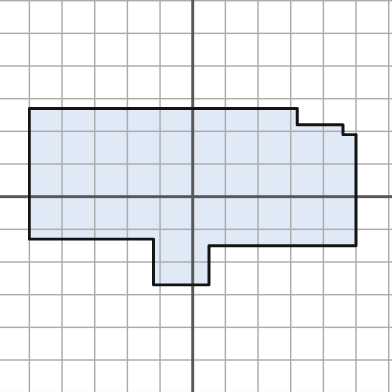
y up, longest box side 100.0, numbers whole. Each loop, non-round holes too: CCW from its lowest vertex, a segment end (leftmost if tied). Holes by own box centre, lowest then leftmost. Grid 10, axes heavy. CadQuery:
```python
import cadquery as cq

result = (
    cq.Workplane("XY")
    .moveTo(-12.0, -27.0)
    .lineTo(5.0, -27.0)
    .lineTo(5.0, -15.0)
    .lineTo(50.0, -15.0)
    .lineTo(50.0, 19.0)
    .lineTo(46.0, 19.0)
    .lineTo(46.0, 22.0)
    .lineTo(32.0, 22.0)
    .lineTo(32.0, 27.0)
    .lineTo(-50.0, 27.0)
    .lineTo(-50.0, -13.0)
    .lineTo(-12.0, -13.0)
    .close()
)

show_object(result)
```